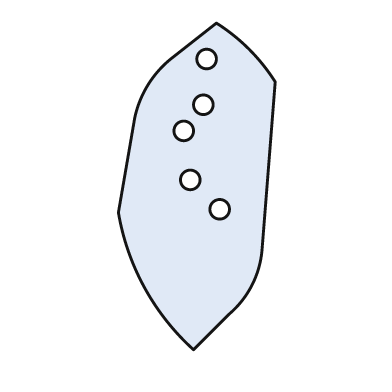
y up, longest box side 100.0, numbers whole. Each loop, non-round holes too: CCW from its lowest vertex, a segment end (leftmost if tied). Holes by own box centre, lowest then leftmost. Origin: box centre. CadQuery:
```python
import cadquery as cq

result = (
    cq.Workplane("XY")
    .moveTo(-1.0, -50.0)
    .lineTo(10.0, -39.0)
    .threePointArc((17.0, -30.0), (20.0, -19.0))
    .lineTo(24.0, 32.0)
    .threePointArc((16.0, 42.0), (6.0, 50.0))
    .lineTo(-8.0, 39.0)
    .threePointArc((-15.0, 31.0), (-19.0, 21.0))
    .lineTo(-24.0, -8.0)
    .threePointArc((-16.0, -31.0), (-1.0, -50.0))
    .close()
    .moveTo(7.0, -7.0)
    .circle(3.0)
    .moveTo(-2.0, 2.0)
    .circle(3.0)
    .moveTo(-4.0, 17.0)
    .circle(3.0)
    .moveTo(2.0, 25.0)
    .circle(3.0)
    .moveTo(3.0, 39.0)
    .circle(3.0)
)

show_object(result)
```